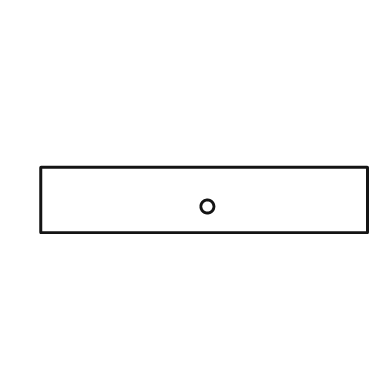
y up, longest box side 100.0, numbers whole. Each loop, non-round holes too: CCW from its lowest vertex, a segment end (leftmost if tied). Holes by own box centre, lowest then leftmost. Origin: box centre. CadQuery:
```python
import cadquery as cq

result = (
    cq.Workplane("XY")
    .moveTo(-50.0, -10.0)
    .lineTo(50.0, -10.0)
    .lineTo(50.0, 10.0)
    .lineTo(-50.0, 10.0)
    .close()
    .moveTo(1.0, -2.0)
    .circle(2.0)
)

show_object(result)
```